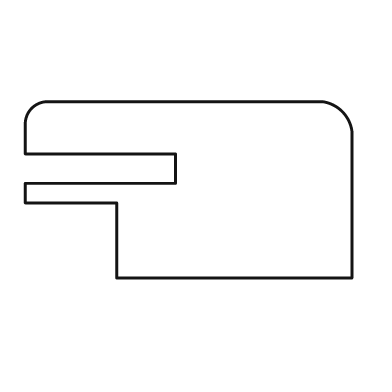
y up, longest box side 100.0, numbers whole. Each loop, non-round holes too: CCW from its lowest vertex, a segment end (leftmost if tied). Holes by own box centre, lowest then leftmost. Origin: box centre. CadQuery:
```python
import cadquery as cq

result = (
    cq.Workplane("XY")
    .moveTo(-22.0, -27.0)
    .lineTo(50.0, -27.0)
    .lineTo(50.0, 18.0)
    .threePointArc((47.0, 24.0), (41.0, 27.0))
    .lineTo(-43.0, 27.0)
    .threePointArc((-48.0, 25.0), (-50.0, 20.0))
    .lineTo(-50.0, 11.0)
    .lineTo(-4.0, 11.0)
    .lineTo(-4.0, 2.0)
    .lineTo(-50.0, 2.0)
    .lineTo(-50.0, -4.0)
    .lineTo(-22.0, -4.0)
    .close()
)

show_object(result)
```